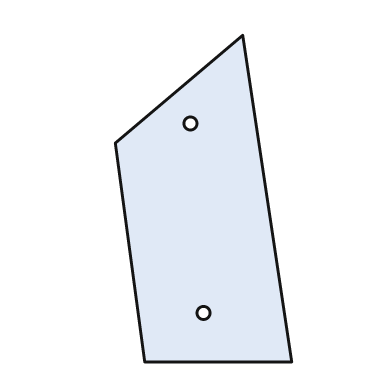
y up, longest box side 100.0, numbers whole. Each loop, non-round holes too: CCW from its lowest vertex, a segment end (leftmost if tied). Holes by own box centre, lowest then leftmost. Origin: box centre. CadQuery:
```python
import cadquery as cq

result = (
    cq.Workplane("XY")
    .moveTo(-18.0, -50.0)
    .lineTo(27.0, -50.0)
    .lineTo(12.0, 50.0)
    .lineTo(-27.0, 17.0)
    .close()
    .moveTo(0.0, -35.0)
    .circle(2.0)
    .moveTo(-4.0, 23.0)
    .circle(2.0)
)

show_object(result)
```